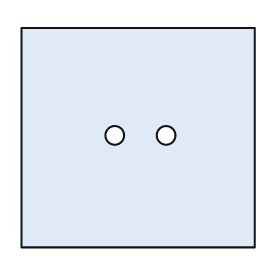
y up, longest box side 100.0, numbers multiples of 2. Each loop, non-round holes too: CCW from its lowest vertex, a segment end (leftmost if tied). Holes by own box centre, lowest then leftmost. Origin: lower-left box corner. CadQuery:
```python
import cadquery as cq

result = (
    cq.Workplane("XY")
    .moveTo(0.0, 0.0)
    .lineTo(100.0, 0.0)
    .lineTo(100.0, 94.0)
    .lineTo(0.0, 94.0)
    .close()
    .moveTo(40.0, 48.0)
    .circle(4.0)
    .moveTo(62.0, 48.0)
    .circle(4.0)
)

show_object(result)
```